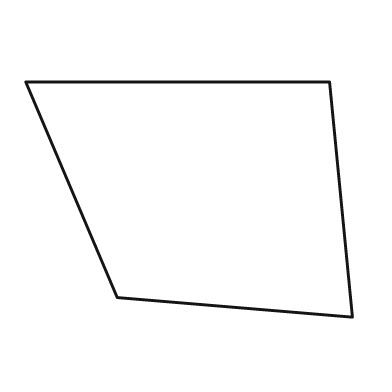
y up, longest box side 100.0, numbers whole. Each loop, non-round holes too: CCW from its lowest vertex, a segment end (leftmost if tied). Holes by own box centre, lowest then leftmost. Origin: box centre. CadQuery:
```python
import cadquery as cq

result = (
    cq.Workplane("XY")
    .moveTo(50.0, -36.0)
    .lineTo(43.0, 36.0)
    .lineTo(-50.0, 36.0)
    .lineTo(-22.0, -30.0)
    .close()
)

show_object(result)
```